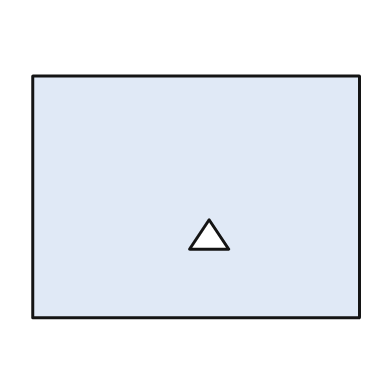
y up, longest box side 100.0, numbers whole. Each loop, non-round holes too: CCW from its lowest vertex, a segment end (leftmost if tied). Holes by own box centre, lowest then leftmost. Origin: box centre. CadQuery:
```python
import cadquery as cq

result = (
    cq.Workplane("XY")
    .moveTo(-50.0, -37.0)
    .lineTo(50.0, -37.0)
    .lineTo(50.0, 37.0)
    .lineTo(-50.0, 37.0)
    .close()
    .moveTo(-2.0, -16.0)
    .lineTo(10.0, -16.0)
    .lineTo(4.0, -7.0)
    .close()
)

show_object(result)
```